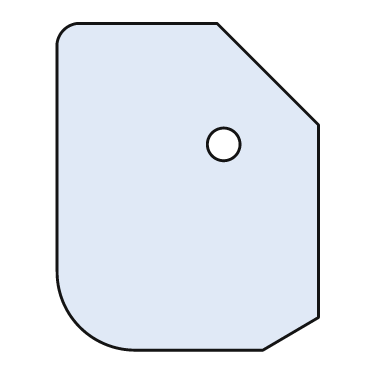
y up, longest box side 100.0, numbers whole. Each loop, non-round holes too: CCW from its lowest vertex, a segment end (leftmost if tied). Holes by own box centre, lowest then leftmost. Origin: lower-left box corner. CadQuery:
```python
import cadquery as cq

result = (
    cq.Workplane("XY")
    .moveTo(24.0, 0.0)
    .lineTo(63.0, 0.0)
    .lineTo(80.0, 10.0)
    .lineTo(80.0, 69.0)
    .lineTo(49.0, 100.0)
    .lineTo(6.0, 100.0)
    .threePointArc((2.0, 98.0), (0.0, 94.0))
    .lineTo(0.0, 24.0)
    .threePointArc((7.0, 7.0), (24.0, 0.0))
    .close()
    .moveTo(51.0, 63.0)
    .circle(5.0)
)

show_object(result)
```